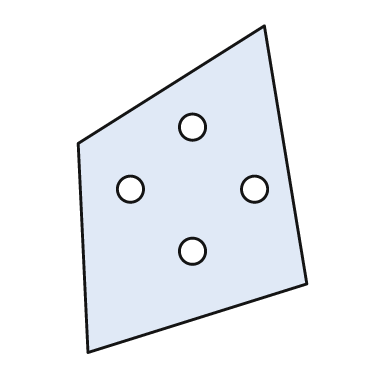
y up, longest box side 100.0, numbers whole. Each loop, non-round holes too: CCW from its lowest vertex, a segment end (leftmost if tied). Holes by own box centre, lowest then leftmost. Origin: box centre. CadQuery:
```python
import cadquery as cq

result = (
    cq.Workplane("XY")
    .moveTo(-32.0, -50.0)
    .lineTo(35.0, -29.0)
    .lineTo(22.0, 50.0)
    .lineTo(-35.0, 14.0)
    .close()
    .moveTo(0.0, -19.0)
    .circle(4.0)
    .moveTo(-19.0, 0.0)
    .circle(4.0)
    .moveTo(19.0, 0.0)
    .circle(4.0)
    .moveTo(0.0, 19.0)
    .circle(4.0)
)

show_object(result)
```